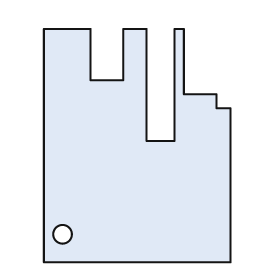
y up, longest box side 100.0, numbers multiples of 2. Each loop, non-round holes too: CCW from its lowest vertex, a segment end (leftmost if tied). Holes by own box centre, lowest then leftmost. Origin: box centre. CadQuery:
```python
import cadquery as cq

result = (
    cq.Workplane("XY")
    .moveTo(-40.0, -50.0)
    .lineTo(40.0, -50.0)
    .lineTo(40.0, 16.0)
    .lineTo(34.0, 16.0)
    .lineTo(34.0, 22.0)
    .lineTo(20.0, 22.0)
    .lineTo(20.0, 50.0)
    .lineTo(16.0, 50.0)
    .lineTo(16.0, 2.0)
    .lineTo(4.0, 2.0)
    .lineTo(4.0, 50.0)
    .lineTo(-6.0, 50.0)
    .lineTo(-6.0, 28.0)
    .lineTo(-20.0, 28.0)
    .lineTo(-20.0, 50.0)
    .lineTo(-40.0, 50.0)
    .close()
    .moveTo(-32.0, -38.0)
    .circle(4.0)
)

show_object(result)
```